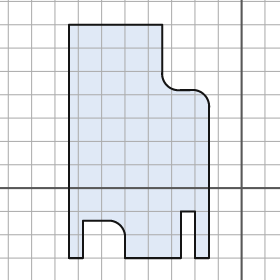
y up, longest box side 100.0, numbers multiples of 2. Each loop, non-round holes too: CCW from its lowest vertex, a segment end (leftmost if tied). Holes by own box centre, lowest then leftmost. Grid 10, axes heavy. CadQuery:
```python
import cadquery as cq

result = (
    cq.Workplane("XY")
    .moveTo(-74.0, -30.0)
    .lineTo(-68.0, -30.0)
    .lineTo(-68.0, -14.0)
    .lineTo(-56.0, -14.0)
    .threePointArc((-52.0, -16.0), (-50.0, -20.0))
    .lineTo(-50.0, -30.0)
    .lineTo(-26.0, -30.0)
    .lineTo(-26.0, -10.0)
    .lineTo(-20.0, -10.0)
    .lineTo(-20.0, -30.0)
    .lineTo(-14.0, -30.0)
    .lineTo(-14.0, 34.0)
    .threePointArc((-16.0, 40.0), (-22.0, 42.0))
    .lineTo(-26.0, 42.0)
    .threePointArc((-32.0, 44.0), (-34.0, 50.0))
    .lineTo(-34.0, 70.0)
    .lineTo(-74.0, 70.0)
    .close()
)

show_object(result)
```